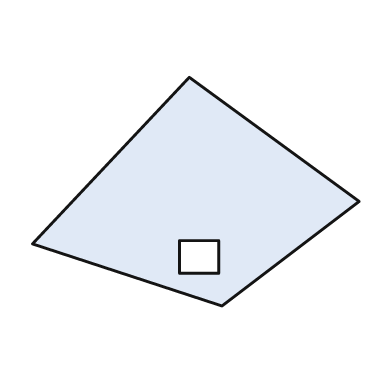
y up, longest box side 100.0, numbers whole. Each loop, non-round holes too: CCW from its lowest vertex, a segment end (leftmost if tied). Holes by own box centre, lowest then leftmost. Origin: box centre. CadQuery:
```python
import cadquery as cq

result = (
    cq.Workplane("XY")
    .moveTo(8.0, -35.0)
    .lineTo(50.0, -3.0)
    .lineTo(-2.0, 35.0)
    .lineTo(-50.0, -16.0)
    .close()
    .moveTo(-5.0, -25.0)
    .lineTo(7.0, -25.0)
    .lineTo(7.0, -15.0)
    .lineTo(-5.0, -15.0)
    .close()
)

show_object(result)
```